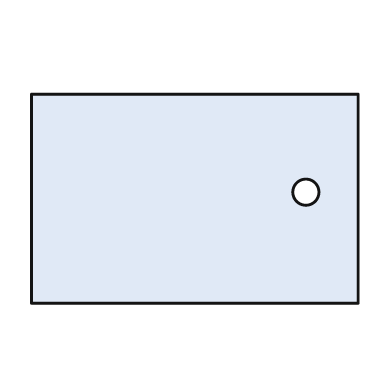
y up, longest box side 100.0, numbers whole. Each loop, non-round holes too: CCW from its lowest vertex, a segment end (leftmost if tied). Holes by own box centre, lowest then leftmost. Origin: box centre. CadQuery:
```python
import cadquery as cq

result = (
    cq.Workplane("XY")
    .moveTo(-50.0, -32.0)
    .lineTo(50.0, -32.0)
    .lineTo(50.0, 32.0)
    .lineTo(-50.0, 32.0)
    .close()
    .moveTo(34.0, 2.0)
    .circle(4.0)
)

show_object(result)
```